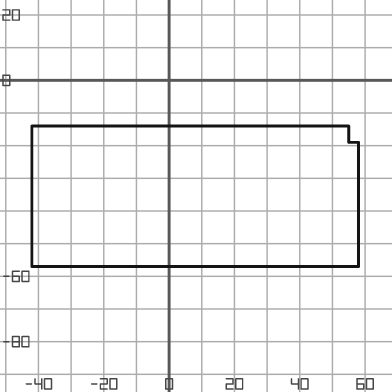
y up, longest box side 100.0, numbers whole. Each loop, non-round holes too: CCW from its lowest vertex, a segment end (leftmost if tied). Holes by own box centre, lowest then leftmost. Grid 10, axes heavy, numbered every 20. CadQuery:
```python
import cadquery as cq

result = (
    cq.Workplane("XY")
    .moveTo(-42.0, -57.0)
    .lineTo(58.0, -57.0)
    .lineTo(58.0, -19.0)
    .lineTo(55.0, -19.0)
    .lineTo(55.0, -14.0)
    .lineTo(-42.0, -14.0)
    .close()
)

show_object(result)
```